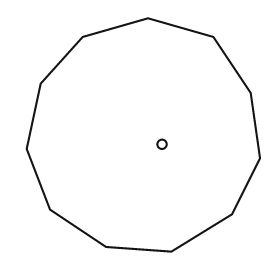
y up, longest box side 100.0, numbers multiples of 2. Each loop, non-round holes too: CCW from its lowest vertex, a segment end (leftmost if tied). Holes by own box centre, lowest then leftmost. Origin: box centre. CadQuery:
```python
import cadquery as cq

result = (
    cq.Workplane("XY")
    .moveTo(12.0, -50.0)
    .lineTo(38.0, -34.0)
    .lineTo(50.0, -10.0)
    .lineTo(46.0, 18.0)
    .lineTo(30.0, 42.0)
    .lineTo(2.0, 50.0)
    .lineTo(-26.0, 42.0)
    .lineTo(-44.0, 22.0)
    .lineTo(-50.0, -6.0)
    .lineTo(-40.0, -32.0)
    .lineTo(-16.0, -48.0)
    .close()
    .moveTo(8.0, -4.0)
    .circle(2.0)
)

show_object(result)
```